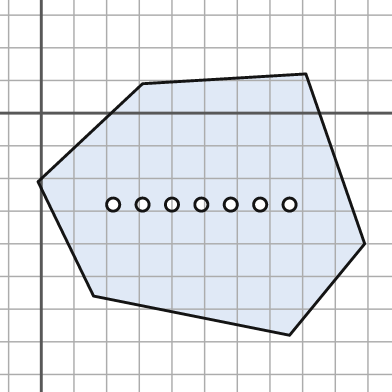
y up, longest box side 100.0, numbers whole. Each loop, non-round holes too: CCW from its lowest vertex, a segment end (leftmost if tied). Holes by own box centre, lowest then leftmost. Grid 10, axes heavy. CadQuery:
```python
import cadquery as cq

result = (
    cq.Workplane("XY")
    .moveTo(76.0, -68.0)
    .lineTo(99.0, -40.0)
    .lineTo(81.0, 12.0)
    .lineTo(31.0, 9.0)
    .lineTo(-1.0, -21.0)
    .lineTo(16.0, -56.0)
    .close()
    .moveTo(22.0, -28.0)
    .circle(2.0)
    .moveTo(31.0, -28.0)
    .circle(2.0)
    .moveTo(40.0, -28.0)
    .circle(2.0)
    .moveTo(49.0, -28.0)
    .circle(2.0)
    .moveTo(58.0, -28.0)
    .circle(2.0)
    .moveTo(67.0, -28.0)
    .circle(2.0)
    .moveTo(76.0, -28.0)
    .circle(2.0)
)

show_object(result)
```